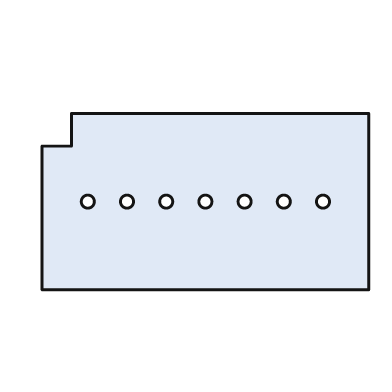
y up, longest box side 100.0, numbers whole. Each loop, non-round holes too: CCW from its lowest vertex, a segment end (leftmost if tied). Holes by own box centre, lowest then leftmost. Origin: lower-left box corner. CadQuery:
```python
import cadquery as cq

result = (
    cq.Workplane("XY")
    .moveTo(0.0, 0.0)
    .lineTo(100.0, 0.0)
    .lineTo(100.0, 54.0)
    .lineTo(9.0, 54.0)
    .lineTo(9.0, 44.0)
    .lineTo(0.0, 44.0)
    .close()
    .moveTo(14.0, 27.0)
    .circle(2.0)
    .moveTo(26.0, 27.0)
    .circle(2.0)
    .moveTo(38.0, 27.0)
    .circle(2.0)
    .moveTo(50.0, 27.0)
    .circle(2.0)
    .moveTo(62.0, 27.0)
    .circle(2.0)
    .moveTo(74.0, 27.0)
    .circle(2.0)
    .moveTo(86.0, 27.0)
    .circle(2.0)
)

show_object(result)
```